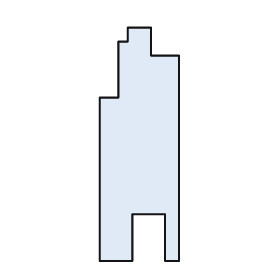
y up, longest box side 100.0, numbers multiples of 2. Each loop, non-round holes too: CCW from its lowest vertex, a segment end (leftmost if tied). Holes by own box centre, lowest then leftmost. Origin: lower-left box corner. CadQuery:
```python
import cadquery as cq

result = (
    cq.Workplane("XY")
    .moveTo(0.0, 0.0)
    .lineTo(14.0, 0.0)
    .lineTo(14.0, 20.0)
    .lineTo(28.0, 20.0)
    .lineTo(28.0, 0.0)
    .lineTo(34.0, 0.0)
    .lineTo(34.0, 88.0)
    .lineTo(22.0, 88.0)
    .lineTo(22.0, 100.0)
    .lineTo(12.0, 100.0)
    .lineTo(12.0, 94.0)
    .lineTo(8.0, 94.0)
    .lineTo(8.0, 70.0)
    .lineTo(0.0, 70.0)
    .close()
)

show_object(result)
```